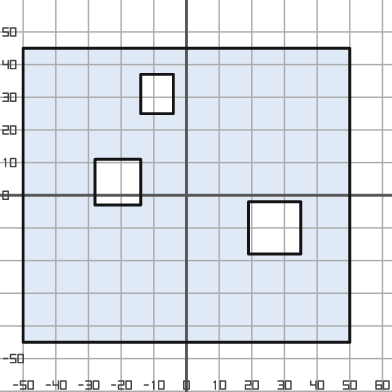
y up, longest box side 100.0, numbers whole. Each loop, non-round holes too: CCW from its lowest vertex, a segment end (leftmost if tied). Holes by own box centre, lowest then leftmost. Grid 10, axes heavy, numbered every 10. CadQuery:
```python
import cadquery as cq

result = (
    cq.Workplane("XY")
    .moveTo(-50.0, -45.0)
    .lineTo(50.0, -45.0)
    .lineTo(50.0, 45.0)
    .lineTo(-50.0, 45.0)
    .close()
    .moveTo(19.0, -18.0)
    .lineTo(35.0, -18.0)
    .lineTo(35.0, -2.0)
    .lineTo(19.0, -2.0)
    .close()
    .moveTo(-28.0, -3.0)
    .lineTo(-14.0, -3.0)
    .lineTo(-14.0, 11.0)
    .lineTo(-28.0, 11.0)
    .close()
    .moveTo(-14.0, 25.0)
    .lineTo(-4.0, 25.0)
    .lineTo(-4.0, 37.0)
    .lineTo(-14.0, 37.0)
    .close()
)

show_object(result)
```